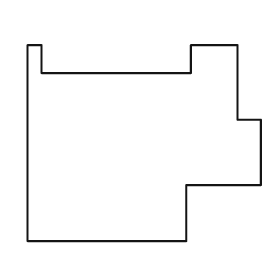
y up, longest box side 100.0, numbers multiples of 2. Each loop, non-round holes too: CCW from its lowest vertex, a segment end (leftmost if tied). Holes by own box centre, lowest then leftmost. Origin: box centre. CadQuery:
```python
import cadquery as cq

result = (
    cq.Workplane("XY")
    .moveTo(-50.0, -42.0)
    .lineTo(18.0, -42.0)
    .lineTo(18.0, -18.0)
    .lineTo(50.0, -18.0)
    .lineTo(50.0, 10.0)
    .lineTo(40.0, 10.0)
    .lineTo(40.0, 42.0)
    .lineTo(20.0, 42.0)
    .lineTo(20.0, 30.0)
    .lineTo(-44.0, 30.0)
    .lineTo(-44.0, 42.0)
    .lineTo(-50.0, 42.0)
    .close()
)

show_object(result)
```